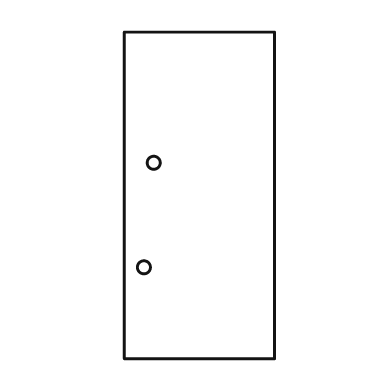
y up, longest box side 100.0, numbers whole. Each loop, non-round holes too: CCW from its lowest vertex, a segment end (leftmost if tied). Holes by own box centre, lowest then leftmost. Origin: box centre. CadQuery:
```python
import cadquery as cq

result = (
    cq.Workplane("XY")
    .moveTo(-23.0, -50.0)
    .lineTo(23.0, -50.0)
    .lineTo(23.0, 50.0)
    .lineTo(-23.0, 50.0)
    .close()
    .moveTo(-17.0, -22.0)
    .circle(2.0)
    .moveTo(-14.0, 10.0)
    .circle(2.0)
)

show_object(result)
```